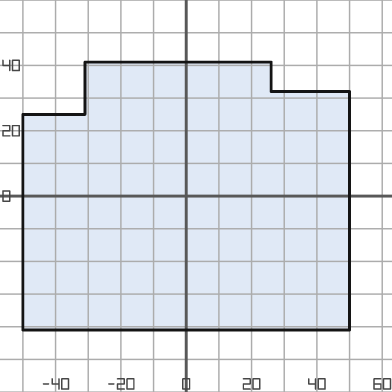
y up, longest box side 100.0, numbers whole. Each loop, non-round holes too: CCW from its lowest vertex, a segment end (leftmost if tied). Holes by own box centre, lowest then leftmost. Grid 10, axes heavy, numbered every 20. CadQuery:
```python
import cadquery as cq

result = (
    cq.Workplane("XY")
    .moveTo(-50.0, -41.0)
    .lineTo(50.0, -41.0)
    .lineTo(50.0, 32.0)
    .lineTo(26.0, 32.0)
    .lineTo(26.0, 41.0)
    .lineTo(-31.0, 41.0)
    .lineTo(-31.0, 25.0)
    .lineTo(-50.0, 25.0)
    .close()
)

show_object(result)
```